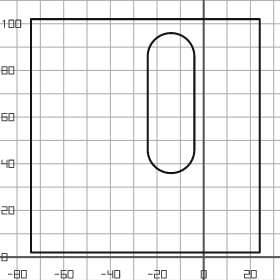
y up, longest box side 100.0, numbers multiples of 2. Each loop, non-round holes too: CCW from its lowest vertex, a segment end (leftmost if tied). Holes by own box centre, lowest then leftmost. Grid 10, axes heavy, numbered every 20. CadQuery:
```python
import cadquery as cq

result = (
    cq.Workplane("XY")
    .moveTo(-74.0, 2.0)
    .lineTo(24.0, 2.0)
    .lineTo(24.0, 102.0)
    .lineTo(-74.0, 102.0)
    .close()
    .moveTo(-24.0, 46.0)
    .threePointArc((-14.0, 36.0), (-4.0, 46.0))
    .lineTo(-4.0, 86.0)
    .threePointArc((-14.0, 96.0), (-24.0, 86.0))
    .close()
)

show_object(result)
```